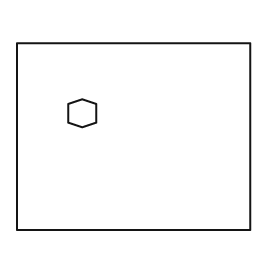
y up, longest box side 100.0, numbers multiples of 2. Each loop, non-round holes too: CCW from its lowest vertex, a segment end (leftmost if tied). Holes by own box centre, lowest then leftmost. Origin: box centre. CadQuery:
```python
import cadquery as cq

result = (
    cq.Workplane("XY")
    .moveTo(-50.0, -40.0)
    .lineTo(50.0, -40.0)
    .lineTo(50.0, 40.0)
    .lineTo(-50.0, 40.0)
    .close()
    .moveTo(-22.0, 4.0)
    .lineTo(-16.0, 6.0)
    .lineTo(-16.0, 14.0)
    .lineTo(-22.0, 16.0)
    .lineTo(-28.0, 14.0)
    .lineTo(-28.0, 6.0)
    .close()
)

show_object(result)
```